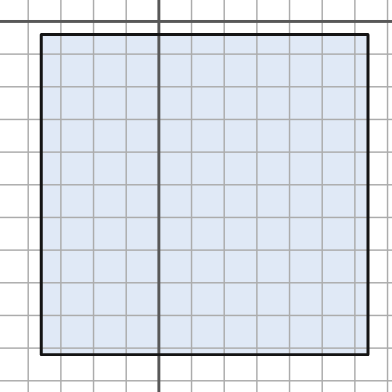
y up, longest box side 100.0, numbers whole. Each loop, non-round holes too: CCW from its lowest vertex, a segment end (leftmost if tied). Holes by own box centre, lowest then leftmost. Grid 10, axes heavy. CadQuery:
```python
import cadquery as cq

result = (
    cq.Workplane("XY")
    .moveTo(-36.0, -102.0)
    .lineTo(64.0, -102.0)
    .lineTo(64.0, -4.0)
    .lineTo(-36.0, -4.0)
    .close()
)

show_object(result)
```